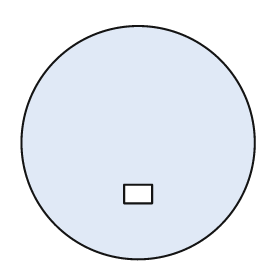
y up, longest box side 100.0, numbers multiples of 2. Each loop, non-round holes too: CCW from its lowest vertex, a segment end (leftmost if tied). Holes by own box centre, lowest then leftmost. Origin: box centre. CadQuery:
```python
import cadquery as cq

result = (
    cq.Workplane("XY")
    .moveTo(0.0, 0.0)
    .circle(50.0)
    .moveTo(-6.0, -26.0)
    .lineTo(6.0, -26.0)
    .lineTo(6.0, -18.0)
    .lineTo(-6.0, -18.0)
    .close()
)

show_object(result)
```